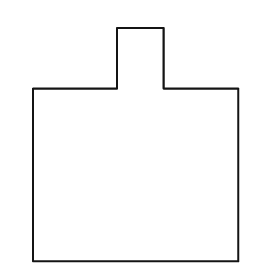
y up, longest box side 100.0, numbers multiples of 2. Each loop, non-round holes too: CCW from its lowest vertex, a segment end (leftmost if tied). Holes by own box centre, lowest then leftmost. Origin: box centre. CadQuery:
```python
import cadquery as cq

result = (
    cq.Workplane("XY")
    .moveTo(-44.0, -50.0)
    .lineTo(44.0, -50.0)
    .lineTo(44.0, 24.0)
    .lineTo(12.0, 24.0)
    .lineTo(12.0, 50.0)
    .lineTo(-8.0, 50.0)
    .lineTo(-8.0, 24.0)
    .lineTo(-44.0, 24.0)
    .close()
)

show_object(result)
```